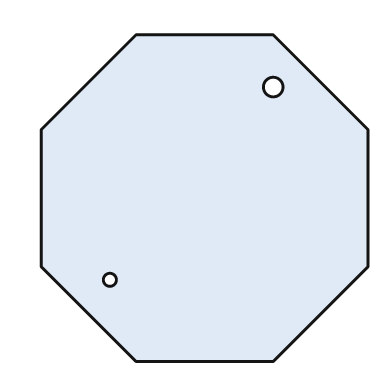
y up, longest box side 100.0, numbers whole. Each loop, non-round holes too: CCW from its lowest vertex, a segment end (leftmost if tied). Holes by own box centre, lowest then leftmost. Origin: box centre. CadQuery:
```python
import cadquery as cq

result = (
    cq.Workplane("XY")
    .moveTo(-21.0, -50.0)
    .lineTo(21.0, -50.0)
    .lineTo(50.0, -21.0)
    .lineTo(50.0, 21.0)
    .lineTo(21.0, 50.0)
    .lineTo(-21.0, 50.0)
    .lineTo(-50.0, 21.0)
    .lineTo(-50.0, -21.0)
    .close()
    .moveTo(-29.0, -25.0)
    .circle(2.0)
    .moveTo(21.0, 34.0)
    .circle(3.0)
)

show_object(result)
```